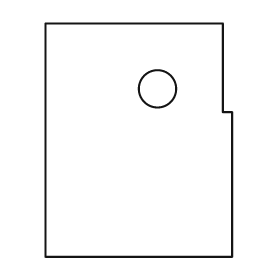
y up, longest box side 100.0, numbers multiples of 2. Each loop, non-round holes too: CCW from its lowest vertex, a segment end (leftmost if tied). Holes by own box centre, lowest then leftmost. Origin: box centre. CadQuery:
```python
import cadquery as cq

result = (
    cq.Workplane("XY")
    .moveTo(-40.0, -50.0)
    .lineTo(40.0, -50.0)
    .lineTo(40.0, 12.0)
    .lineTo(36.0, 12.0)
    .lineTo(36.0, 50.0)
    .lineTo(-40.0, 50.0)
    .close()
    .moveTo(8.0, 22.0)
    .circle(8.0)
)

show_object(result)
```